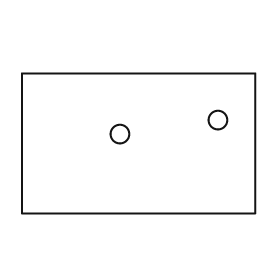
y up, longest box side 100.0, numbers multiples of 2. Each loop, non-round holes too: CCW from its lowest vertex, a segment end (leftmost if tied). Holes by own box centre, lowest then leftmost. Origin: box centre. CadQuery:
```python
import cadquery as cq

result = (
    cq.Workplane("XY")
    .moveTo(-50.0, -30.0)
    .lineTo(50.0, -30.0)
    .lineTo(50.0, 30.0)
    .lineTo(-50.0, 30.0)
    .close()
    .moveTo(-8.0, 4.0)
    .circle(4.0)
    .moveTo(34.0, 10.0)
    .circle(4.0)
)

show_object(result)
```